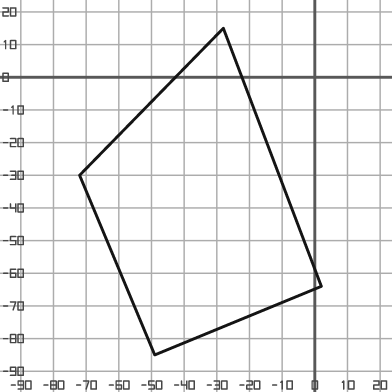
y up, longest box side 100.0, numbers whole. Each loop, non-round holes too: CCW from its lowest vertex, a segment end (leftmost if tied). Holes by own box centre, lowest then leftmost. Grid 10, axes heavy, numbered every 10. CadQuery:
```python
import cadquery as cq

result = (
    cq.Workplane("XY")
    .moveTo(-49.0, -85.0)
    .lineTo(2.0, -64.0)
    .lineTo(-28.0, 15.0)
    .lineTo(-72.0, -30.0)
    .close()
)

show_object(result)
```